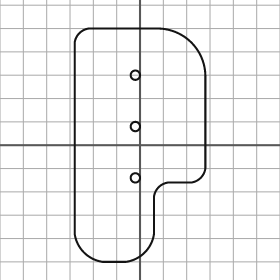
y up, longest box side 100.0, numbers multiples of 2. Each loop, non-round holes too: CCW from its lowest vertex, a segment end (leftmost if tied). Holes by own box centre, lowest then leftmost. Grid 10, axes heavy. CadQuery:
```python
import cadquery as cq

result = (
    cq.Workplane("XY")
    .moveTo(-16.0, -50.0)
    .lineTo(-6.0, -50.0)
    .threePointArc((2.0, -46.0), (6.0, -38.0))
    .lineTo(6.0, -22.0)
    .threePointArc((8.0, -18.0), (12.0, -16.0))
    .lineTo(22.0, -16.0)
    .threePointArc((26.0, -14.0), (28.0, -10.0))
    .lineTo(28.0, 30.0)
    .threePointArc((22.0, 44.0), (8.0, 50.0))
    .lineTo(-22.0, 50.0)
    .threePointArc((-26.0, 48.0), (-28.0, 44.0))
    .lineTo(-28.0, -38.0)
    .threePointArc((-24.0, -46.0), (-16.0, -50.0))
    .close()
    .moveTo(-2.0, -14.0)
    .circle(2.0)
    .moveTo(-2.0, 8.0)
    .circle(2.0)
    .moveTo(-2.0, 30.0)
    .circle(2.0)
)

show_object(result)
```